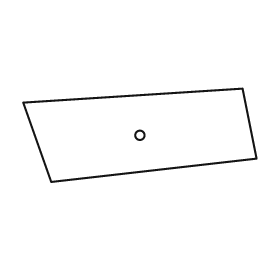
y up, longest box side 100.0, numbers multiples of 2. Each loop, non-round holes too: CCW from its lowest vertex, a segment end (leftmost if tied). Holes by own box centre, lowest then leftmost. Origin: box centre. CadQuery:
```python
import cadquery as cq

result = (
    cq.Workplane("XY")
    .moveTo(-38.0, -20.0)
    .lineTo(50.0, -10.0)
    .lineTo(44.0, 20.0)
    .lineTo(-50.0, 14.0)
    .close()
    .moveTo(0.0, 0.0)
    .circle(2.0)
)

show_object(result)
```